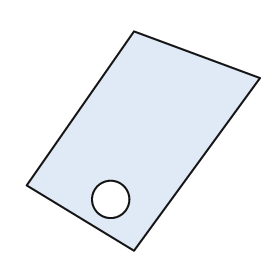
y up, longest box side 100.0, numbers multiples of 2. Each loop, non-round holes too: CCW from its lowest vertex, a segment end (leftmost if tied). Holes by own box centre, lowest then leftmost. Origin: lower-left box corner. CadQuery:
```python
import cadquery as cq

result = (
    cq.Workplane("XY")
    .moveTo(46.0, 0.0)
    .lineTo(100.0, 74.0)
    .lineTo(46.0, 94.0)
    .lineTo(0.0, 28.0)
    .close()
    .moveTo(36.0, 22.0)
    .circle(8.0)
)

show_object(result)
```